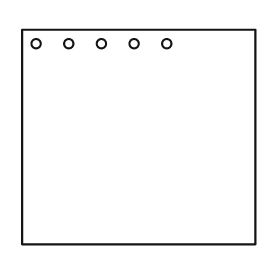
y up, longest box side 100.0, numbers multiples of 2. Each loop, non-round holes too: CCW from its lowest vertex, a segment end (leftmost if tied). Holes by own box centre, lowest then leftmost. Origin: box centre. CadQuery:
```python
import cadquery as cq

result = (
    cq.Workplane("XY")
    .moveTo(-50.0, -46.0)
    .lineTo(50.0, -46.0)
    .lineTo(50.0, 46.0)
    .lineTo(-50.0, 46.0)
    .close()
    .moveTo(-44.0, 40.0)
    .circle(2.0)
    .moveTo(-30.0, 40.0)
    .circle(2.0)
    .moveTo(-16.0, 40.0)
    .circle(2.0)
    .moveTo(-2.0, 40.0)
    .circle(2.0)
    .moveTo(12.0, 40.0)
    .circle(2.0)
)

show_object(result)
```